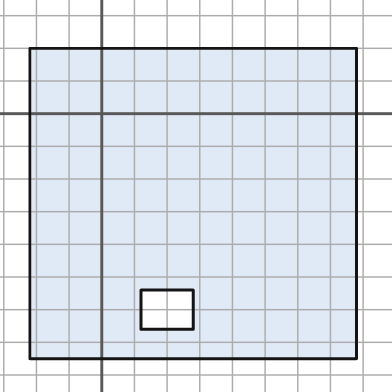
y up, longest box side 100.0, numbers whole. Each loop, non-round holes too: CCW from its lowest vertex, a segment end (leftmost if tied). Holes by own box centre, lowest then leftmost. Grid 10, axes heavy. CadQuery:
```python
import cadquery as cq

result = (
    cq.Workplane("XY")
    .moveTo(-22.0, -75.0)
    .lineTo(78.0, -75.0)
    .lineTo(78.0, 20.0)
    .lineTo(-22.0, 20.0)
    .close()
    .moveTo(12.0, -66.0)
    .lineTo(28.0, -66.0)
    .lineTo(28.0, -54.0)
    .lineTo(12.0, -54.0)
    .close()
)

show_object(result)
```